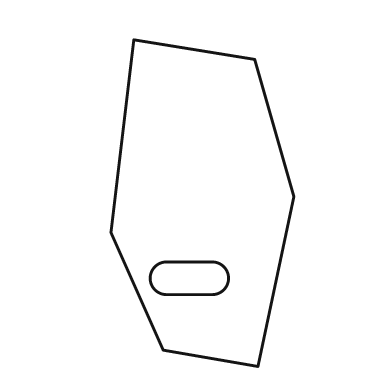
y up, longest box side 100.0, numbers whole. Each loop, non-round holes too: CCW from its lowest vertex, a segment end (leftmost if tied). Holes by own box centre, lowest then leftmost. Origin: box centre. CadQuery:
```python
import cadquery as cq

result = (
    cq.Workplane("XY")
    .moveTo(17.0, -50.0)
    .lineTo(28.0, 2.0)
    .lineTo(16.0, 44.0)
    .lineTo(-21.0, 50.0)
    .lineTo(-28.0, -9.0)
    .lineTo(-12.0, -45.0)
    .close()
    .moveTo(-11.0, -28.0)
    .lineTo(3.0, -28.0)
    .threePointArc((8.0, -23.0), (3.0, -18.0))
    .lineTo(-11.0, -18.0)
    .threePointArc((-16.0, -23.0), (-11.0, -28.0))
    .close()
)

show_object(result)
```